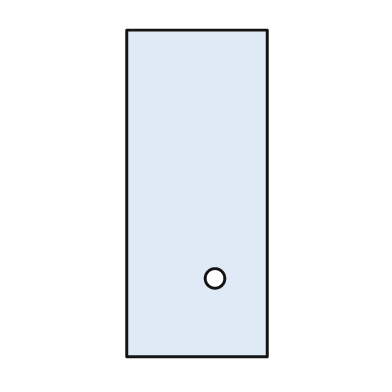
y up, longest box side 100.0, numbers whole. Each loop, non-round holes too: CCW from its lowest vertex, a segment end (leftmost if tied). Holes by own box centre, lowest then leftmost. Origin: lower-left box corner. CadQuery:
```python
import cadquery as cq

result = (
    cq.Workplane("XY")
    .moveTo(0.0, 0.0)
    .lineTo(43.0, 0.0)
    .lineTo(43.0, 100.0)
    .lineTo(0.0, 100.0)
    .close()
    .moveTo(27.0, 24.0)
    .circle(3.0)
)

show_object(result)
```